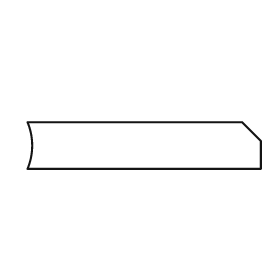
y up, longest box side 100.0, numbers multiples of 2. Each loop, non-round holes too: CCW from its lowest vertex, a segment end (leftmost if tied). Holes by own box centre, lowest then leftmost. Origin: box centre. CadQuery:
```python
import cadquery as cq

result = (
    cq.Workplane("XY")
    .moveTo(-50.0, -10.0)
    .lineTo(50.0, -10.0)
    .lineTo(50.0, 2.0)
    .lineTo(42.0, 10.0)
    .lineTo(-50.0, 10.0)
    .threePointArc((-48.0, 0.0), (-50.0, -10.0))
    .close()
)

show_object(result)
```